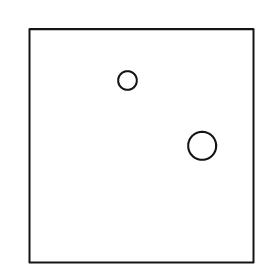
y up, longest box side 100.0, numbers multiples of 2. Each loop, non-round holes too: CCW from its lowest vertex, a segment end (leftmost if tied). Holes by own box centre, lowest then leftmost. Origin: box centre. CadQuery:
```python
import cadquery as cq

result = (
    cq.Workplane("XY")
    .moveTo(-48.0, -50.0)
    .lineTo(48.0, -50.0)
    .lineTo(48.0, 50.0)
    .lineTo(-48.0, 50.0)
    .close()
    .moveTo(26.0, 0.0)
    .circle(6.0)
    .moveTo(-6.0, 28.0)
    .circle(4.0)
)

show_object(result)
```